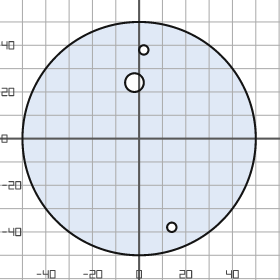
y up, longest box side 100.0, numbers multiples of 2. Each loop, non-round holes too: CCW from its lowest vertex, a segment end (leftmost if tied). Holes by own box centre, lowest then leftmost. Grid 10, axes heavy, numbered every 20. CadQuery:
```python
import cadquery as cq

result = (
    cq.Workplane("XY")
    .moveTo(0.0, 0.0)
    .circle(50.0)
    .moveTo(14.0, -38.0)
    .circle(2.0)
    .moveTo(-2.0, 24.0)
    .circle(4.0)
    .moveTo(2.0, 38.0)
    .circle(2.0)
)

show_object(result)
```